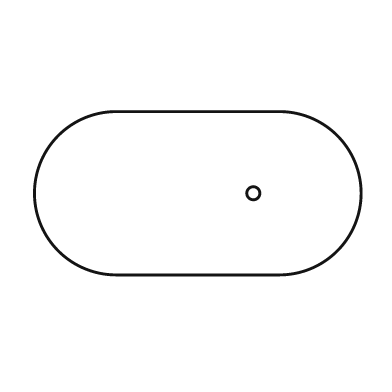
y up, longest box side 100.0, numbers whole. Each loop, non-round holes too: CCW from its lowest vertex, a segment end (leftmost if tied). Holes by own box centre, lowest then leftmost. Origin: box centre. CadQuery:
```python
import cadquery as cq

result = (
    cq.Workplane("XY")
    .moveTo(-25.0, -25.0)
    .lineTo(25.0, -25.0)
    .threePointArc((50.0, 0.0), (25.0, 25.0))
    .lineTo(-25.0, 25.0)
    .threePointArc((-50.0, 0.0), (-25.0, -25.0))
    .close()
    .moveTo(17.0, 0.0)
    .circle(2.0)
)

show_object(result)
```